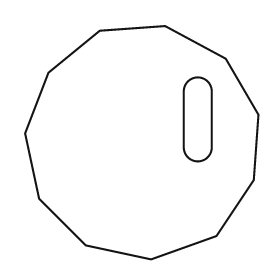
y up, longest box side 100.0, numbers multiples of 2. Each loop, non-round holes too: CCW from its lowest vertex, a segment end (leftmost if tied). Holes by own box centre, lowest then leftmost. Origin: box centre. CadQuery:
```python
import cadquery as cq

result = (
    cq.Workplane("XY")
    .moveTo(4.0, -50.0)
    .lineTo(32.0, -40.0)
    .lineTo(48.0, -16.0)
    .lineTo(50.0, 12.0)
    .lineTo(36.0, 36.0)
    .lineTo(10.0, 50.0)
    .lineTo(-18.0, 48.0)
    .lineTo(-40.0, 30.0)
    .lineTo(-50.0, 4.0)
    .lineTo(-44.0, -24.0)
    .lineTo(-24.0, -44.0)
    .close()
    .moveTo(18.0, -2.0)
    .threePointArc((24.0, -8.0), (30.0, -2.0))
    .lineTo(30.0, 22.0)
    .threePointArc((24.0, 28.0), (18.0, 22.0))
    .close()
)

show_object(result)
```